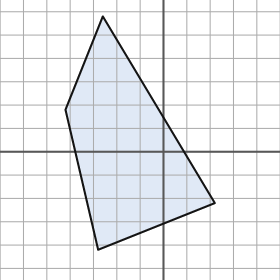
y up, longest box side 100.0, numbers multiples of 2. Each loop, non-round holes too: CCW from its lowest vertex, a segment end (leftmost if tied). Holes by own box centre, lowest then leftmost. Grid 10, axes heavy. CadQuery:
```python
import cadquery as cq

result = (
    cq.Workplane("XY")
    .moveTo(-28.0, -42.0)
    .lineTo(22.0, -22.0)
    .lineTo(-26.0, 58.0)
    .lineTo(-42.0, 18.0)
    .close()
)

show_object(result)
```